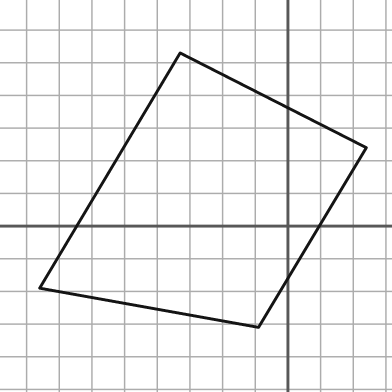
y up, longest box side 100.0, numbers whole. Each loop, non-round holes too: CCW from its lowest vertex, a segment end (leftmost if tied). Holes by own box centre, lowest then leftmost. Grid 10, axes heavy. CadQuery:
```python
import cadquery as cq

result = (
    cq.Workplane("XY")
    .moveTo(-9.0, -31.0)
    .lineTo(24.0, 24.0)
    .lineTo(-33.0, 53.0)
    .lineTo(-76.0, -19.0)
    .close()
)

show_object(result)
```